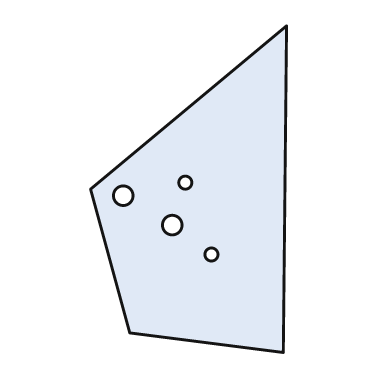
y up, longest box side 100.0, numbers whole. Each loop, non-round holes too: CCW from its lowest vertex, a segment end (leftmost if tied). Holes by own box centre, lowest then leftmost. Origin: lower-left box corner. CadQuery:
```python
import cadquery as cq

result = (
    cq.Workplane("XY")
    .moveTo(59.0, 0.0)
    .lineTo(60.0, 100.0)
    .lineTo(0.0, 50.0)
    .lineTo(12.0, 6.0)
    .close()
    .moveTo(37.0, 30.0)
    .circle(2.0)
    .moveTo(25.0, 39.0)
    .circle(3.0)
    .moveTo(10.0, 48.0)
    .circle(3.0)
    .moveTo(29.0, 52.0)
    .circle(2.0)
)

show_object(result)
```